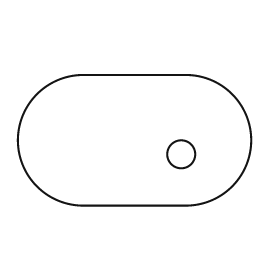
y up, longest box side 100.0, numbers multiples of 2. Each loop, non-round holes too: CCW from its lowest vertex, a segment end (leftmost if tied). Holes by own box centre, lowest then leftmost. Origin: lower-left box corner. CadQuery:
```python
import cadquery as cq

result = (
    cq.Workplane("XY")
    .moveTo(28.0, 0.0)
    .lineTo(72.0, 0.0)
    .threePointArc((100.0, 28.0), (72.0, 56.0))
    .lineTo(28.0, 56.0)
    .threePointArc((0.0, 28.0), (28.0, 0.0))
    .close()
    .moveTo(70.0, 22.0)
    .circle(6.0)
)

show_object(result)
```